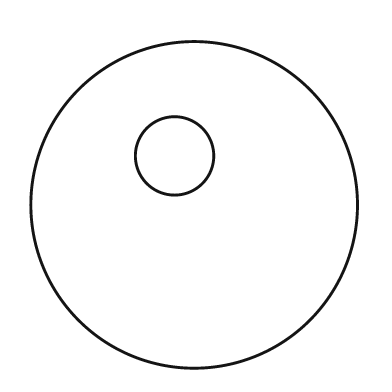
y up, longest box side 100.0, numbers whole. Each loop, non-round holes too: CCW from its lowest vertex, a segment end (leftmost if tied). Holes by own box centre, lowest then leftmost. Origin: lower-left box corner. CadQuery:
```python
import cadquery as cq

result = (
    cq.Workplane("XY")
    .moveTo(50.0, 50.0)
    .circle(50.0)
    .moveTo(44.0, 65.0)
    .circle(12.0)
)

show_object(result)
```